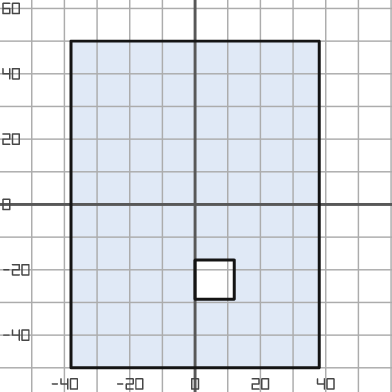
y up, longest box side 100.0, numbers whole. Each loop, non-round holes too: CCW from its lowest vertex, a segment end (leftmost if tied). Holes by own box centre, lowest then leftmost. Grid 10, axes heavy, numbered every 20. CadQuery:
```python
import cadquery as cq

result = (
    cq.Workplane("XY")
    .moveTo(-38.0, -50.0)
    .lineTo(38.0, -50.0)
    .lineTo(38.0, 50.0)
    .lineTo(-38.0, 50.0)
    .close()
    .moveTo(0.0, -29.0)
    .lineTo(12.0, -29.0)
    .lineTo(12.0, -17.0)
    .lineTo(0.0, -17.0)
    .close()
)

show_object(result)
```